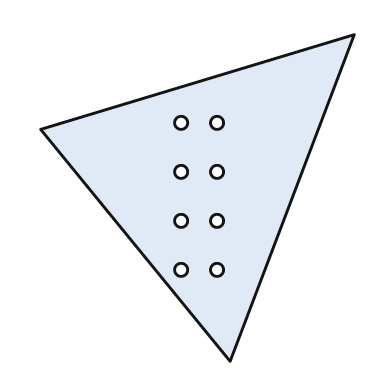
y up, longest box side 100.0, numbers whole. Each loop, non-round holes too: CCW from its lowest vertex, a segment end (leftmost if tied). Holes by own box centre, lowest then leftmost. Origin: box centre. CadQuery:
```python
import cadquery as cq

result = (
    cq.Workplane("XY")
    .moveTo(10.0, -50.0)
    .lineTo(48.0, 50.0)
    .lineTo(-48.0, 21.0)
    .close()
    .moveTo(-5.0, -22.0)
    .circle(2.0)
    .moveTo(6.0, -22.0)
    .circle(2.0)
    .moveTo(-5.0, -7.0)
    .circle(2.0)
    .moveTo(6.0, -7.0)
    .circle(2.0)
    .moveTo(-5.0, 8.0)
    .circle(2.0)
    .moveTo(6.0, 8.0)
    .circle(2.0)
    .moveTo(-5.0, 23.0)
    .circle(2.0)
    .moveTo(6.0, 23.0)
    .circle(2.0)
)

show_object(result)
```